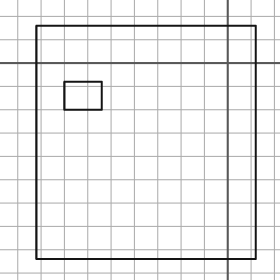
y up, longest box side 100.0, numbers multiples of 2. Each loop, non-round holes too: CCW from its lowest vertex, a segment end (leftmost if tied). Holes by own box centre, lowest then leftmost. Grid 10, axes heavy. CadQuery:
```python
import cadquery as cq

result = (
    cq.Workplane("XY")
    .moveTo(-82.0, -84.0)
    .lineTo(12.0, -84.0)
    .lineTo(12.0, 16.0)
    .lineTo(-82.0, 16.0)
    .close()
    .moveTo(-70.0, -20.0)
    .lineTo(-54.0, -20.0)
    .lineTo(-54.0, -8.0)
    .lineTo(-70.0, -8.0)
    .close()
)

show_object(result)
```